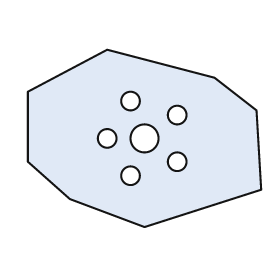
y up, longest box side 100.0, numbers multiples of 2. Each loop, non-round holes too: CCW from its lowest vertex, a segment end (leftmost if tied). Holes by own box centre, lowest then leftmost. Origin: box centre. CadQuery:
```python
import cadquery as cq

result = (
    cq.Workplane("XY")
    .moveTo(0.0, -38.0)
    .lineTo(50.0, -22.0)
    .lineTo(48.0, 12.0)
    .lineTo(30.0, 26.0)
    .lineTo(-16.0, 38.0)
    .lineTo(-50.0, 20.0)
    .lineTo(-50.0, -10.0)
    .lineTo(-32.0, -26.0)
    .close()
    .moveTo(-6.0, -16.0)
    .circle(4.0)
    .moveTo(14.0, -10.0)
    .circle(4.0)
    .moveTo(-16.0, 0.0)
    .circle(4.0)
    .moveTo(0.0, 0.0)
    .circle(6.0)
    .moveTo(14.0, 10.0)
    .circle(4.0)
    .moveTo(-6.0, 16.0)
    .circle(4.0)
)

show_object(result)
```